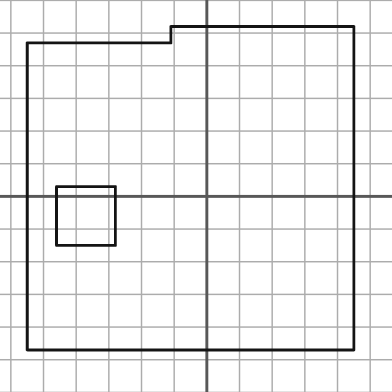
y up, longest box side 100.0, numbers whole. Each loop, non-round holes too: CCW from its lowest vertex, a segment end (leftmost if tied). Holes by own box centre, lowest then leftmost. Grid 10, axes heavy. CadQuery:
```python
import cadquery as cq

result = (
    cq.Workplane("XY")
    .moveTo(-55.0, -47.0)
    .lineTo(45.0, -47.0)
    .lineTo(45.0, 52.0)
    .lineTo(-11.0, 52.0)
    .lineTo(-11.0, 47.0)
    .lineTo(-55.0, 47.0)
    .close()
    .moveTo(-46.0, -15.0)
    .lineTo(-28.0, -15.0)
    .lineTo(-28.0, 3.0)
    .lineTo(-46.0, 3.0)
    .close()
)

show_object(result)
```